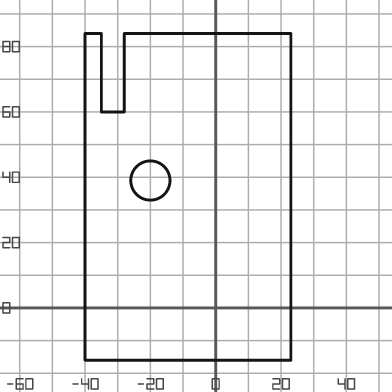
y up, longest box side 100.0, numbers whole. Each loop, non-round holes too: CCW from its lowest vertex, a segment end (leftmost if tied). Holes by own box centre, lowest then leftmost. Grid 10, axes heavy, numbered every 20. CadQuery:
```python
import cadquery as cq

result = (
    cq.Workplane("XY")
    .moveTo(-40.0, -16.0)
    .lineTo(23.0, -16.0)
    .lineTo(23.0, 84.0)
    .lineTo(-28.0, 84.0)
    .lineTo(-28.0, 60.0)
    .lineTo(-35.0, 60.0)
    .lineTo(-35.0, 84.0)
    .lineTo(-40.0, 84.0)
    .close()
    .moveTo(-20.0, 39.0)
    .circle(6.0)
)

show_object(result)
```